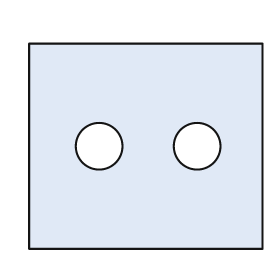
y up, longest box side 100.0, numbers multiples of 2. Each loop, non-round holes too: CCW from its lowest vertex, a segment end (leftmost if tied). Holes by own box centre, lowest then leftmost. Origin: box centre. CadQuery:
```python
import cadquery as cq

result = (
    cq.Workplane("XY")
    .moveTo(-50.0, -44.0)
    .lineTo(50.0, -44.0)
    .lineTo(50.0, 44.0)
    .lineTo(-50.0, 44.0)
    .close()
    .moveTo(-20.0, 0.0)
    .circle(10.0)
    .moveTo(22.0, 0.0)
    .circle(10.0)
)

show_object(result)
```